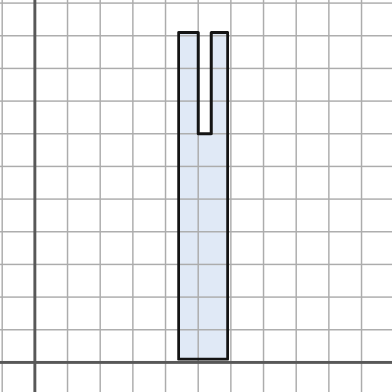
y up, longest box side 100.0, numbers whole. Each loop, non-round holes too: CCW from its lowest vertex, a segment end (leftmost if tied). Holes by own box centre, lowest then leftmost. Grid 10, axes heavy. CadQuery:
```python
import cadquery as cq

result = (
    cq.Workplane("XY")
    .moveTo(44.0, 1.0)
    .lineTo(59.0, 1.0)
    .lineTo(59.0, 101.0)
    .lineTo(54.0, 101.0)
    .lineTo(54.0, 70.0)
    .lineTo(50.0, 70.0)
    .lineTo(50.0, 101.0)
    .lineTo(44.0, 101.0)
    .close()
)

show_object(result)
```